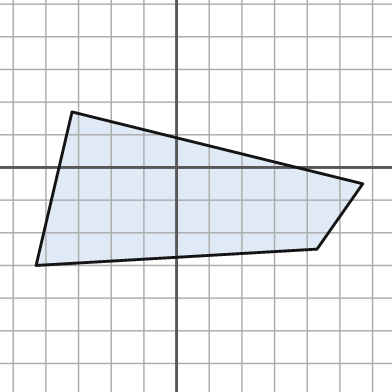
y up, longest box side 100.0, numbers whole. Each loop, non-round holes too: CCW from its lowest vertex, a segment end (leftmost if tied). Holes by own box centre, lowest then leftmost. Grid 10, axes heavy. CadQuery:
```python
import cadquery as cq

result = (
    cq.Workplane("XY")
    .moveTo(-43.0, -30.0)
    .lineTo(43.0, -25.0)
    .lineTo(57.0, -5.0)
    .lineTo(-32.0, 17.0)
    .close()
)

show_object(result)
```